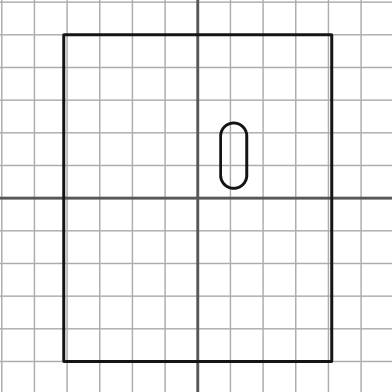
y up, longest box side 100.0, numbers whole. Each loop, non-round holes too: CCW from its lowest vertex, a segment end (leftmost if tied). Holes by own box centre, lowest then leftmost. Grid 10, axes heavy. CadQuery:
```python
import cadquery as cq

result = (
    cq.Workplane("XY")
    .moveTo(-41.0, -50.0)
    .lineTo(41.0, -50.0)
    .lineTo(41.0, 50.0)
    .lineTo(-41.0, 50.0)
    .close()
    .moveTo(7.0, 7.0)
    .threePointArc((11.0, 3.0), (15.0, 7.0))
    .lineTo(15.0, 19.0)
    .threePointArc((11.0, 23.0), (7.0, 19.0))
    .close()
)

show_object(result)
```